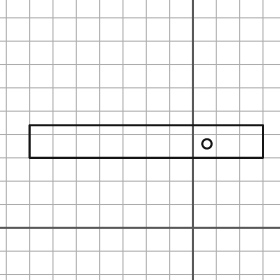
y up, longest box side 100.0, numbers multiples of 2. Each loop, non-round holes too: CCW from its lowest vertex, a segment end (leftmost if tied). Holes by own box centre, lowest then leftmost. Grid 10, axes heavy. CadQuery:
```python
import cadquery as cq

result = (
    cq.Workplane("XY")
    .moveTo(-70.0, 30.0)
    .lineTo(30.0, 30.0)
    .lineTo(30.0, 44.0)
    .lineTo(-70.0, 44.0)
    .close()
    .moveTo(6.0, 36.0)
    .circle(2.0)
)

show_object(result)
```